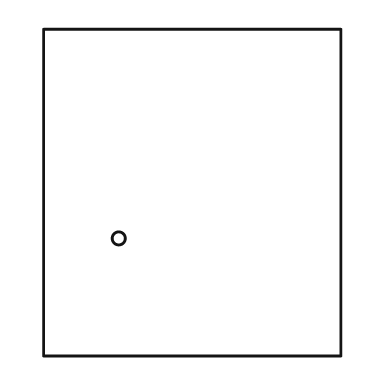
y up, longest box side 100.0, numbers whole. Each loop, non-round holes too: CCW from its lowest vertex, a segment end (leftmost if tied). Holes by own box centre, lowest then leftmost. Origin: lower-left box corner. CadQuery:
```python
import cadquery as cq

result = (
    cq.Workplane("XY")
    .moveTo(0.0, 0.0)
    .lineTo(91.0, 0.0)
    .lineTo(91.0, 100.0)
    .lineTo(0.0, 100.0)
    .close()
    .moveTo(23.0, 36.0)
    .circle(2.0)
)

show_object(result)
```